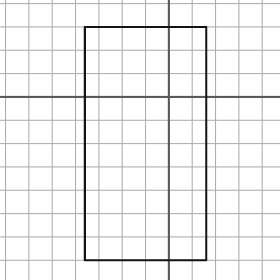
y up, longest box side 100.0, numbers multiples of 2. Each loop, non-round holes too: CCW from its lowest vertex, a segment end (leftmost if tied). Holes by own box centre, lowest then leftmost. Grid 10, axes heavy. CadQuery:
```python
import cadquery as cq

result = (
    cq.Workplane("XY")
    .moveTo(-36.0, -70.0)
    .lineTo(16.0, -70.0)
    .lineTo(16.0, 30.0)
    .lineTo(-36.0, 30.0)
    .close()
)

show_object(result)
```